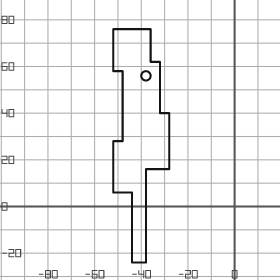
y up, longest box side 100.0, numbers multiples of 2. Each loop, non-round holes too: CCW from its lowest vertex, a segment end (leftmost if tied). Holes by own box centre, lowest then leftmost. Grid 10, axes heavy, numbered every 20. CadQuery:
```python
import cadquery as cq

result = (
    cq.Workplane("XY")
    .moveTo(-44.0, -24.0)
    .lineTo(-38.0, -24.0)
    .lineTo(-38.0, 16.0)
    .lineTo(-28.0, 16.0)
    .lineTo(-28.0, 40.0)
    .lineTo(-32.0, 40.0)
    .lineTo(-32.0, 62.0)
    .lineTo(-36.0, 62.0)
    .lineTo(-36.0, 76.0)
    .lineTo(-52.0, 76.0)
    .lineTo(-52.0, 58.0)
    .lineTo(-48.0, 58.0)
    .lineTo(-48.0, 28.0)
    .lineTo(-52.0, 28.0)
    .lineTo(-52.0, 6.0)
    .lineTo(-44.0, 6.0)
    .close()
    .moveTo(-38.0, 56.0)
    .circle(2.0)
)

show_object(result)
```